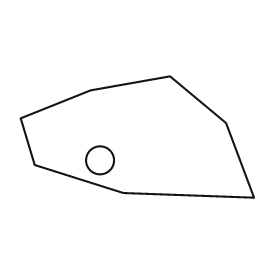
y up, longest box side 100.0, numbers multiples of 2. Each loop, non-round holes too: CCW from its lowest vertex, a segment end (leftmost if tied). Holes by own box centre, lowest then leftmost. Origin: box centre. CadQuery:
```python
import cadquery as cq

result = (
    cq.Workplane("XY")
    .moveTo(50.0, -26.0)
    .lineTo(38.0, 6.0)
    .lineTo(14.0, 26.0)
    .lineTo(-20.0, 20.0)
    .lineTo(-50.0, 8.0)
    .lineTo(-44.0, -12.0)
    .lineTo(-6.0, -24.0)
    .close()
    .moveTo(-16.0, -10.0)
    .circle(6.0)
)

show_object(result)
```